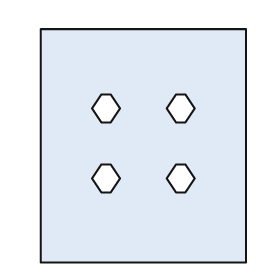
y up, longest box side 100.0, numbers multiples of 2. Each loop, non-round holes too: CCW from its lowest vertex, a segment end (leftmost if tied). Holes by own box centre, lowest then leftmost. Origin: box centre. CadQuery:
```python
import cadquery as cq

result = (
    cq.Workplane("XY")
    .moveTo(-44.0, -50.0)
    .lineTo(44.0, -50.0)
    .lineTo(44.0, 50.0)
    .lineTo(-44.0, 50.0)
    .close()
    .moveTo(-18.0, -20.0)
    .lineTo(-14.0, -20.0)
    .lineTo(-10.0, -14.0)
    .lineTo(-14.0, -8.0)
    .lineTo(-18.0, -8.0)
    .lineTo(-22.0, -14.0)
    .close()
    .moveTo(14.0, -20.0)
    .lineTo(18.0, -20.0)
    .lineTo(22.0, -14.0)
    .lineTo(18.0, -8.0)
    .lineTo(14.0, -8.0)
    .lineTo(10.0, -14.0)
    .close()
    .moveTo(-18.0, 10.0)
    .lineTo(-14.0, 10.0)
    .lineTo(-10.0, 16.0)
    .lineTo(-14.0, 22.0)
    .lineTo(-18.0, 22.0)
    .lineTo(-22.0, 16.0)
    .close()
    .moveTo(14.0, 10.0)
    .lineTo(18.0, 10.0)
    .lineTo(22.0, 16.0)
    .lineTo(18.0, 22.0)
    .lineTo(14.0, 22.0)
    .lineTo(10.0, 16.0)
    .close()
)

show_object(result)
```